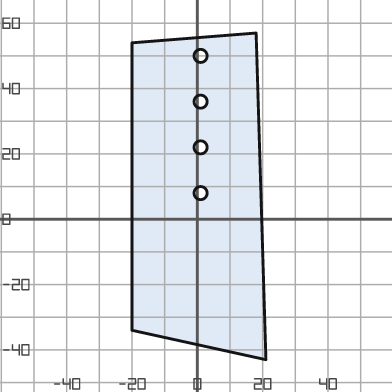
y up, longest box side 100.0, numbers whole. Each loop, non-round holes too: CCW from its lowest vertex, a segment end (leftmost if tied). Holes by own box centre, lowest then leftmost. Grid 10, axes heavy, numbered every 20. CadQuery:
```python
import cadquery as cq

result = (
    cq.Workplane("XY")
    .moveTo(21.0, -43.0)
    .lineTo(18.0, 57.0)
    .lineTo(-20.0, 54.0)
    .lineTo(-20.0, -34.0)
    .close()
    .moveTo(1.0, 8.0)
    .circle(2.0)
    .moveTo(1.0, 22.0)
    .circle(2.0)
    .moveTo(1.0, 36.0)
    .circle(2.0)
    .moveTo(1.0, 50.0)
    .circle(2.0)
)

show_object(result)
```